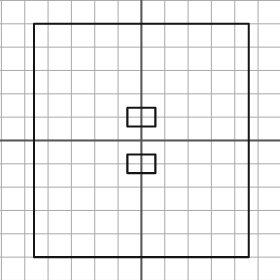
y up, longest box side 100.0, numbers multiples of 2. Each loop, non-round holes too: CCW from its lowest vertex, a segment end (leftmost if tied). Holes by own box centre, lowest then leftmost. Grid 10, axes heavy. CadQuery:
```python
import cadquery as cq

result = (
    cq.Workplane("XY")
    .moveTo(-46.0, -50.0)
    .lineTo(46.0, -50.0)
    .lineTo(46.0, 50.0)
    .lineTo(-46.0, 50.0)
    .close()
    .moveTo(-6.0, -14.0)
    .lineTo(6.0, -14.0)
    .lineTo(6.0, -6.0)
    .lineTo(-6.0, -6.0)
    .close()
    .moveTo(-6.0, 6.0)
    .lineTo(6.0, 6.0)
    .lineTo(6.0, 14.0)
    .lineTo(-6.0, 14.0)
    .close()
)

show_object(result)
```